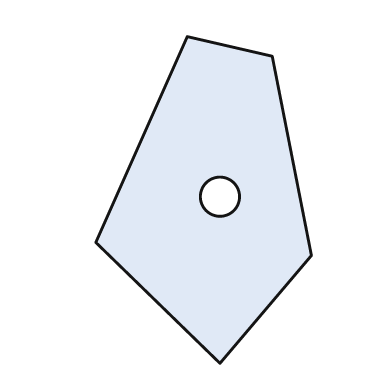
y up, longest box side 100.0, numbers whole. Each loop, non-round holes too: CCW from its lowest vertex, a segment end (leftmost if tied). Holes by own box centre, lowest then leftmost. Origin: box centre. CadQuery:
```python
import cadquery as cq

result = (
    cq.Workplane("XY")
    .moveTo(5.0, -50.0)
    .lineTo(33.0, -17.0)
    .lineTo(21.0, 44.0)
    .lineTo(-5.0, 50.0)
    .lineTo(-33.0, -13.0)
    .close()
    .moveTo(5.0, 1.0)
    .circle(6.0)
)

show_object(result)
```